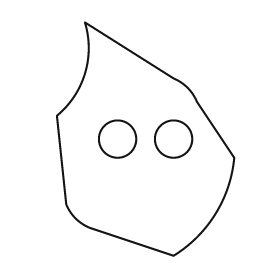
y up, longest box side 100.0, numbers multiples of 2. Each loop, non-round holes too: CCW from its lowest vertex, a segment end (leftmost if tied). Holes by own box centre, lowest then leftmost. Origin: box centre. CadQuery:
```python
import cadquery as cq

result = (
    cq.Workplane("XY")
    .moveTo(12.0, -50.0)
    .threePointArc((30.0, -32.0), (38.0, -8.0))
    .lineTo(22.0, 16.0)
    .threePointArc((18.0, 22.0), (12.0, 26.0))
    .lineTo(-26.0, 50.0)
    .threePointArc((-26.0, 28.0), (-38.0, 10.0))
    .lineTo(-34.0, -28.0)
    .threePointArc((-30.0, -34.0), (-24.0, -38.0))
    .close()
    .moveTo(-12.0, 0.0)
    .circle(8.0)
    .moveTo(12.0, 0.0)
    .circle(8.0)
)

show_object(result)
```